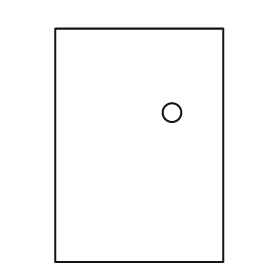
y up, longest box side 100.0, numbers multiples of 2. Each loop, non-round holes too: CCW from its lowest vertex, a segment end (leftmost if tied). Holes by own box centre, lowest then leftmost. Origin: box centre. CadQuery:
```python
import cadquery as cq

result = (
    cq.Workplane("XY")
    .moveTo(-36.0, -50.0)
    .lineTo(36.0, -50.0)
    .lineTo(36.0, 50.0)
    .lineTo(-36.0, 50.0)
    .close()
    .moveTo(14.0, 14.0)
    .circle(4.0)
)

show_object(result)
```